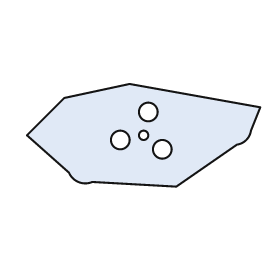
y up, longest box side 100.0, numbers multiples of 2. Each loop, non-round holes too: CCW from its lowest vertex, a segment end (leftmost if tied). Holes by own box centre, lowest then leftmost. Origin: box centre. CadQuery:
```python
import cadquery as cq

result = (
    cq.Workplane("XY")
    .moveTo(14.0, -22.0)
    .lineTo(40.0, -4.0)
    .threePointArc((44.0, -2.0), (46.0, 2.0))
    .lineTo(50.0, 12.0)
    .lineTo(-6.0, 22.0)
    .lineTo(-34.0, 16.0)
    .lineTo(-50.0, 0.0)
    .lineTo(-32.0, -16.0)
    .threePointArc((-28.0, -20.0), (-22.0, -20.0))
    .close()
    .moveTo(8.0, -6.0)
    .circle(4.0)
    .moveTo(-10.0, -2.0)
    .circle(4.0)
    .moveTo(0.0, 0.0)
    .circle(2.0)
    .moveTo(2.0, 10.0)
    .circle(4.0)
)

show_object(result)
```